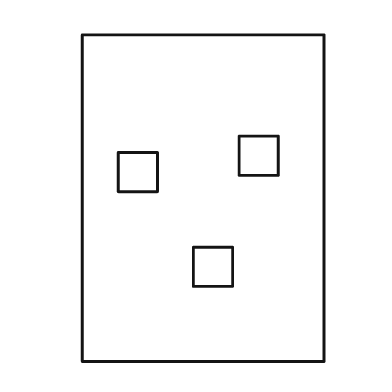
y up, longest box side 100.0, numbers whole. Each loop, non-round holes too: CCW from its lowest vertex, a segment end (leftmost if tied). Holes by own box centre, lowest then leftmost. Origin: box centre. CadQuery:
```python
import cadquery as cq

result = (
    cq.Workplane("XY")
    .moveTo(-37.0, -50.0)
    .lineTo(37.0, -50.0)
    .lineTo(37.0, 50.0)
    .lineTo(-37.0, 50.0)
    .close()
    .moveTo(-3.0, -27.0)
    .lineTo(9.0, -27.0)
    .lineTo(9.0, -15.0)
    .lineTo(-3.0, -15.0)
    .close()
    .moveTo(-26.0, 2.0)
    .lineTo(-14.0, 2.0)
    .lineTo(-14.0, 14.0)
    .lineTo(-26.0, 14.0)
    .close()
    .moveTo(11.0, 7.0)
    .lineTo(23.0, 7.0)
    .lineTo(23.0, 19.0)
    .lineTo(11.0, 19.0)
    .close()
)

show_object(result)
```